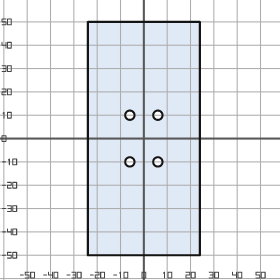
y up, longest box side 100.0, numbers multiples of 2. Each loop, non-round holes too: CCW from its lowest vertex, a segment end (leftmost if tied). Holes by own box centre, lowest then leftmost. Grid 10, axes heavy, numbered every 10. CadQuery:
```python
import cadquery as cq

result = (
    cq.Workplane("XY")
    .moveTo(-24.0, -50.0)
    .lineTo(24.0, -50.0)
    .lineTo(24.0, 50.0)
    .lineTo(-24.0, 50.0)
    .close()
    .moveTo(-6.0, -10.0)
    .circle(2.0)
    .moveTo(6.0, -10.0)
    .circle(2.0)
    .moveTo(-6.0, 10.0)
    .circle(2.0)
    .moveTo(6.0, 10.0)
    .circle(2.0)
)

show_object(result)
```